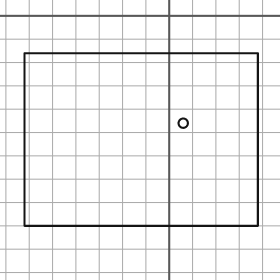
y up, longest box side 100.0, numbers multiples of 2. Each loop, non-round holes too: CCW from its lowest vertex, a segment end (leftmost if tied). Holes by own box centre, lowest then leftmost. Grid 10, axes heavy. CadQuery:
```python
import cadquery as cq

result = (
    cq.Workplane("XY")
    .moveTo(-62.0, -90.0)
    .lineTo(38.0, -90.0)
    .lineTo(38.0, -16.0)
    .lineTo(-62.0, -16.0)
    .close()
    .moveTo(6.0, -46.0)
    .circle(2.0)
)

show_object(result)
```